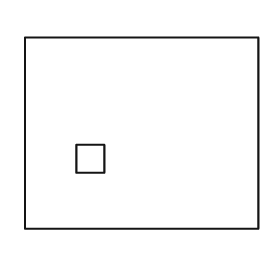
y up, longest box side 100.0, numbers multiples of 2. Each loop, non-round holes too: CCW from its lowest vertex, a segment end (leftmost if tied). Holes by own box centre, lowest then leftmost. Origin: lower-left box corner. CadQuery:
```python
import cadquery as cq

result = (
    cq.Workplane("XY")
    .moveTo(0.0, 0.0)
    .lineTo(100.0, 0.0)
    .lineTo(100.0, 82.0)
    .lineTo(0.0, 82.0)
    .close()
    .moveTo(22.0, 24.0)
    .lineTo(34.0, 24.0)
    .lineTo(34.0, 36.0)
    .lineTo(22.0, 36.0)
    .close()
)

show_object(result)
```